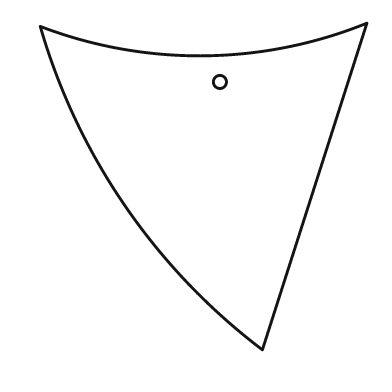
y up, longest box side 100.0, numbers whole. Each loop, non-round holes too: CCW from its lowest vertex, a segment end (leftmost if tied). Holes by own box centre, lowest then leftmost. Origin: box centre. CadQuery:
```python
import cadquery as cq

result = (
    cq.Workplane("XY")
    .moveTo(18.0, -50.0)
    .lineTo(50.0, 50.0)
    .threePointArc((0.0, 40.0), (-50.0, 49.0))
    .threePointArc((-24.0, -6.0), (18.0, -50.0))
    .close()
    .moveTo(5.0, 32.0)
    .circle(2.0)
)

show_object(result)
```